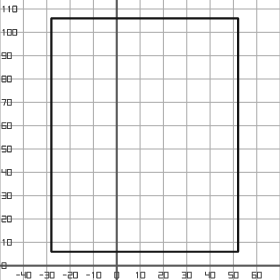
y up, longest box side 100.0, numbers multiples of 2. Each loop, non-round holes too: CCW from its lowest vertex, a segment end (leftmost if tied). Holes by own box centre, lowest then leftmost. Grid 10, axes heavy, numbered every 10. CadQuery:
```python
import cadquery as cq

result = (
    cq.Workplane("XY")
    .moveTo(-28.0, 6.0)
    .lineTo(52.0, 6.0)
    .lineTo(52.0, 106.0)
    .lineTo(-28.0, 106.0)
    .close()
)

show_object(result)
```